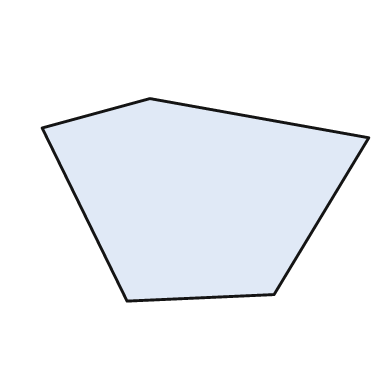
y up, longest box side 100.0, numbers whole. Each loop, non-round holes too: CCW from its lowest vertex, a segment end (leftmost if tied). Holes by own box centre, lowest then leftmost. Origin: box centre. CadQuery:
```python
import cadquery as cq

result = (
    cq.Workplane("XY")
    .moveTo(-24.0, -31.0)
    .lineTo(21.0, -29.0)
    .lineTo(50.0, 19.0)
    .lineTo(-17.0, 31.0)
    .lineTo(-50.0, 22.0)
    .close()
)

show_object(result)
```